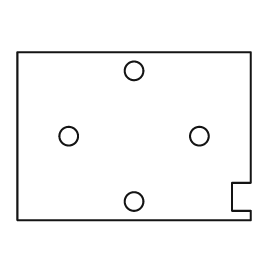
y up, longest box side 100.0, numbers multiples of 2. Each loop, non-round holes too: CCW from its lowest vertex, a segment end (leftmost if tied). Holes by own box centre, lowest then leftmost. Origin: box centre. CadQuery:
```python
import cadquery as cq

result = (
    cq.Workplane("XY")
    .moveTo(-50.0, -36.0)
    .lineTo(50.0, -36.0)
    .lineTo(50.0, -32.0)
    .lineTo(42.0, -32.0)
    .lineTo(42.0, -20.0)
    .lineTo(50.0, -20.0)
    .lineTo(50.0, 36.0)
    .lineTo(-50.0, 36.0)
    .close()
    .moveTo(0.0, -28.0)
    .circle(4.0)
    .moveTo(-28.0, 0.0)
    .circle(4.0)
    .moveTo(28.0, 0.0)
    .circle(4.0)
    .moveTo(0.0, 28.0)
    .circle(4.0)
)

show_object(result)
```